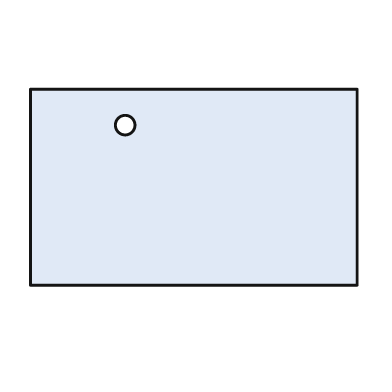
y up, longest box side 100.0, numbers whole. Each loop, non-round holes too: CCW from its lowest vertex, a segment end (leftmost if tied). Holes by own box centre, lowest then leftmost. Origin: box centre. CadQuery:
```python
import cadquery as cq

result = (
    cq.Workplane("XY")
    .moveTo(-50.0, -30.0)
    .lineTo(50.0, -30.0)
    .lineTo(50.0, 30.0)
    .lineTo(-50.0, 30.0)
    .close()
    .moveTo(-21.0, 19.0)
    .circle(3.0)
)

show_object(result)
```